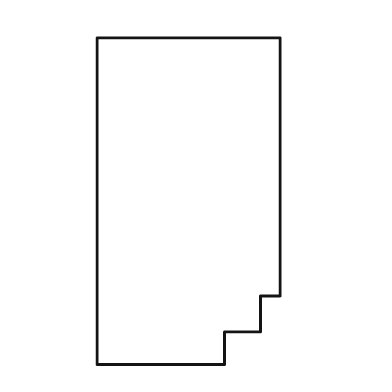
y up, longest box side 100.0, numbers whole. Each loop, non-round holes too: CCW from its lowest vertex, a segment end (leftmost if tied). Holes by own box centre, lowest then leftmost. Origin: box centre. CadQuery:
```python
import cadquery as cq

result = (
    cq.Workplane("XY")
    .moveTo(-28.0, -50.0)
    .lineTo(11.0, -50.0)
    .lineTo(11.0, -40.0)
    .lineTo(22.0, -40.0)
    .lineTo(22.0, -29.0)
    .lineTo(28.0, -29.0)
    .lineTo(28.0, 50.0)
    .lineTo(-28.0, 50.0)
    .close()
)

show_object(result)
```